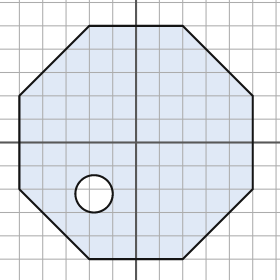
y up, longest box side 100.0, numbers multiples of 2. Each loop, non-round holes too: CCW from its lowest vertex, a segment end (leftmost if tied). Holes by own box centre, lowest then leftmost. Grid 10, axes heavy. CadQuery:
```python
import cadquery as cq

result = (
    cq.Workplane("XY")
    .moveTo(-20.0, -50.0)
    .lineTo(20.0, -50.0)
    .lineTo(50.0, -20.0)
    .lineTo(50.0, 20.0)
    .lineTo(20.0, 50.0)
    .lineTo(-20.0, 50.0)
    .lineTo(-50.0, 20.0)
    .lineTo(-50.0, -20.0)
    .close()
    .moveTo(-18.0, -22.0)
    .circle(8.0)
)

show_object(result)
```